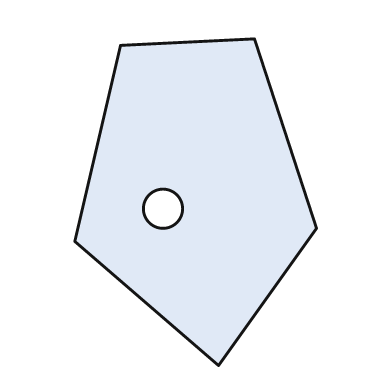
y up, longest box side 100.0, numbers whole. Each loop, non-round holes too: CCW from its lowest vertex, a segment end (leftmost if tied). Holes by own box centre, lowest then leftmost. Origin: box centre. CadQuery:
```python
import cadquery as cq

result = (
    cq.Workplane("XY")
    .moveTo(7.0, -50.0)
    .lineTo(37.0, -8.0)
    .lineTo(18.0, 50.0)
    .lineTo(-23.0, 48.0)
    .lineTo(-37.0, -12.0)
    .close()
    .moveTo(-10.0, -2.0)
    .circle(6.0)
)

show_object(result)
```